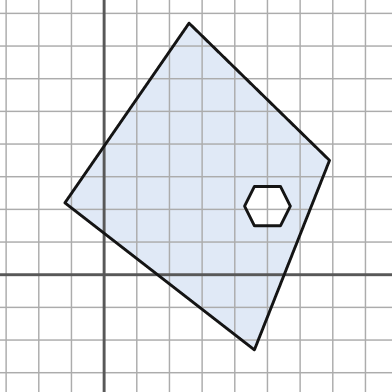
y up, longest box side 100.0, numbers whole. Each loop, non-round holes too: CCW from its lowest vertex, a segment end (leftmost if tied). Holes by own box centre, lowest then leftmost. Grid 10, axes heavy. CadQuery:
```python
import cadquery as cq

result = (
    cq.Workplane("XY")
    .moveTo(46.0, -23.0)
    .lineTo(69.0, 35.0)
    .lineTo(26.0, 77.0)
    .lineTo(-12.0, 22.0)
    .close()
    .moveTo(46.0, 15.0)
    .lineTo(54.0, 15.0)
    .lineTo(57.0, 21.0)
    .lineTo(54.0, 27.0)
    .lineTo(46.0, 27.0)
    .lineTo(43.0, 21.0)
    .close()
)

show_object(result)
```